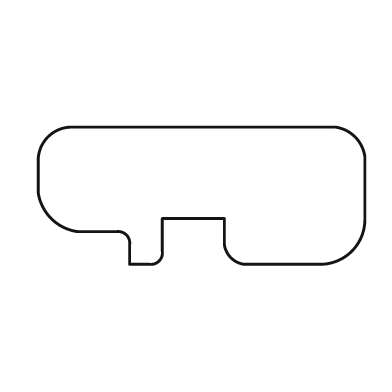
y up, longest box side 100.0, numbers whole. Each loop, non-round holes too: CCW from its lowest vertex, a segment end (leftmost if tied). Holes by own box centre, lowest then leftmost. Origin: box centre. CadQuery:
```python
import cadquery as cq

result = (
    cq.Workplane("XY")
    .moveTo(-22.0, -21.0)
    .lineTo(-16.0, -21.0)
    .threePointArc((-13.0, -20.0), (-12.0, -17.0))
    .lineTo(-12.0, -7.0)
    .lineTo(7.0, -7.0)
    .lineTo(7.0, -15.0)
    .threePointArc((9.0, -19.0), (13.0, -21.0))
    .lineTo(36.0, -21.0)
    .threePointArc((46.0, -17.0), (50.0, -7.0))
    .lineTo(50.0, 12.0)
    .threePointArc((47.0, 18.0), (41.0, 21.0))
    .lineTo(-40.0, 21.0)
    .threePointArc((-47.0, 18.0), (-50.0, 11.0))
    .lineTo(-50.0, 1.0)
    .threePointArc((-46.0, -7.0), (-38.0, -11.0))
    .lineTo(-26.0, -11.0)
    .threePointArc((-23.0, -12.0), (-22.0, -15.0))
    .close()
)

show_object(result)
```